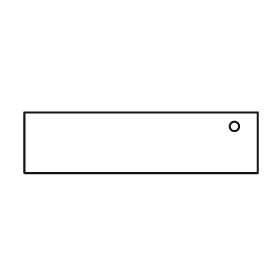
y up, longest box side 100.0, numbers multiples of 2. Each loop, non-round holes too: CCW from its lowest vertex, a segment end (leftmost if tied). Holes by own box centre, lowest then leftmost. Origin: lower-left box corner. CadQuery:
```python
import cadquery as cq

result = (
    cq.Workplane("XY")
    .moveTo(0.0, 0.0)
    .lineTo(100.0, 0.0)
    .lineTo(100.0, 26.0)
    .lineTo(0.0, 26.0)
    .close()
    .moveTo(90.0, 20.0)
    .circle(2.0)
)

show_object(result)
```